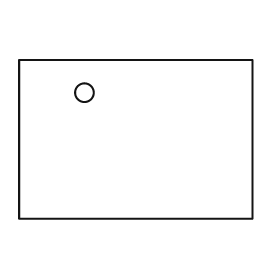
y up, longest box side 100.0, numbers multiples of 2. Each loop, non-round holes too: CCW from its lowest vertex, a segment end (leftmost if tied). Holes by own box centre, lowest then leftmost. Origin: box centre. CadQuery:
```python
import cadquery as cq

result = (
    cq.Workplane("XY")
    .moveTo(-50.0, -34.0)
    .lineTo(50.0, -34.0)
    .lineTo(50.0, 34.0)
    .lineTo(-50.0, 34.0)
    .close()
    .moveTo(-22.0, 20.0)
    .circle(4.0)
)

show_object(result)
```